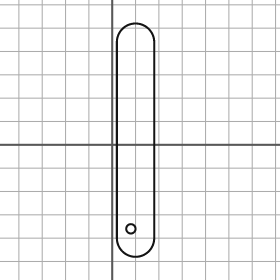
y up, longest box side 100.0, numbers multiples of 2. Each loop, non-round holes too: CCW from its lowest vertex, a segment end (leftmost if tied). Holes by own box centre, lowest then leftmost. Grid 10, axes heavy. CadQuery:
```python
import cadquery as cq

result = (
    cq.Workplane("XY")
    .moveTo(2.0, -40.0)
    .threePointArc((10.0, -48.0), (18.0, -40.0))
    .lineTo(18.0, 44.0)
    .threePointArc((10.0, 52.0), (2.0, 44.0))
    .close()
    .moveTo(8.0, -36.0)
    .circle(2.0)
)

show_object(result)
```